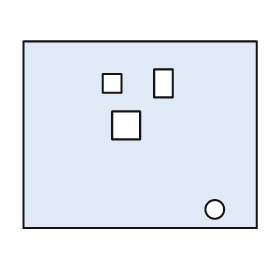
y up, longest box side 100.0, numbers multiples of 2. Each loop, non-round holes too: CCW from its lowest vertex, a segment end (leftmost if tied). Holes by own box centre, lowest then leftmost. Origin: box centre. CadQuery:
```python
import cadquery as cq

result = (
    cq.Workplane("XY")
    .moveTo(-50.0, -40.0)
    .lineTo(50.0, -40.0)
    .lineTo(50.0, 40.0)
    .lineTo(-50.0, 40.0)
    .close()
    .moveTo(32.0, -32.0)
    .circle(4.0)
    .moveTo(-12.0, -2.0)
    .lineTo(0.0, -2.0)
    .lineTo(0.0, 10.0)
    .lineTo(-12.0, 10.0)
    .close()
    .moveTo(-16.0, 18.0)
    .lineTo(-8.0, 18.0)
    .lineTo(-8.0, 26.0)
    .lineTo(-16.0, 26.0)
    .close()
    .moveTo(6.0, 16.0)
    .lineTo(14.0, 16.0)
    .lineTo(14.0, 28.0)
    .lineTo(6.0, 28.0)
    .close()
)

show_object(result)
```